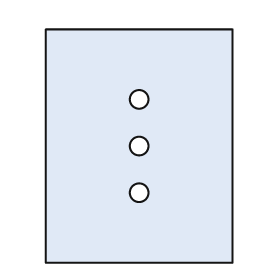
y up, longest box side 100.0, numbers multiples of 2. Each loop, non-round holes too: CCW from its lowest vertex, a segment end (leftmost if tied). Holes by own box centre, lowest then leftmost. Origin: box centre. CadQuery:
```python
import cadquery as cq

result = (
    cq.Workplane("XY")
    .moveTo(-40.0, -50.0)
    .lineTo(40.0, -50.0)
    .lineTo(40.0, 50.0)
    .lineTo(-40.0, 50.0)
    .close()
    .moveTo(0.0, -20.0)
    .circle(4.0)
    .moveTo(0.0, 0.0)
    .circle(4.0)
    .moveTo(0.0, 20.0)
    .circle(4.0)
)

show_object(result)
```